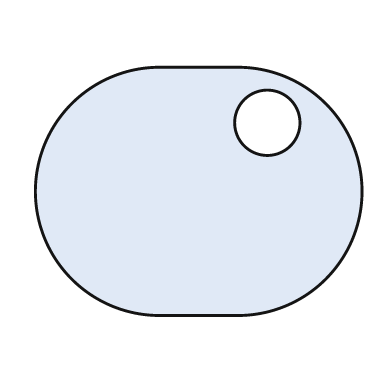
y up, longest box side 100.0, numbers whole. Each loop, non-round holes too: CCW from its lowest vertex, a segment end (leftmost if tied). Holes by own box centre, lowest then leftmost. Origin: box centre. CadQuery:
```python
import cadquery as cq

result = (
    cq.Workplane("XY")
    .moveTo(-12.0, -38.0)
    .lineTo(12.0, -38.0)
    .threePointArc((50.0, 0.0), (12.0, 38.0))
    .lineTo(-12.0, 38.0)
    .threePointArc((-50.0, 0.0), (-12.0, -38.0))
    .close()
    .moveTo(21.0, 21.0)
    .circle(10.0)
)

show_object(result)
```